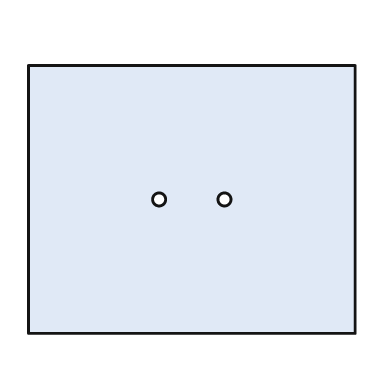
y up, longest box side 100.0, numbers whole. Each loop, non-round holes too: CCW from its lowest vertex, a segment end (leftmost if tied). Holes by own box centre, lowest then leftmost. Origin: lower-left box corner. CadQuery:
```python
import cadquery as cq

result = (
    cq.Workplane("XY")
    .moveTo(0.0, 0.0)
    .lineTo(100.0, 0.0)
    .lineTo(100.0, 82.0)
    .lineTo(0.0, 82.0)
    .close()
    .moveTo(40.0, 41.0)
    .circle(2.0)
    .moveTo(60.0, 41.0)
    .circle(2.0)
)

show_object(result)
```